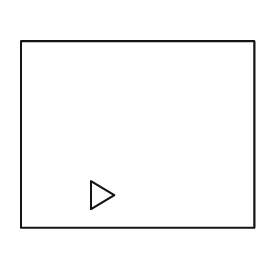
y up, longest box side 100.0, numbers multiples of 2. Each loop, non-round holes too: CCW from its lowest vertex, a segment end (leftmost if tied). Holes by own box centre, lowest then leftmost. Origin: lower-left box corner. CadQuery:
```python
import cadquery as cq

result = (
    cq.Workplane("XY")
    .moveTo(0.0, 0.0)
    .lineTo(100.0, 0.0)
    .lineTo(100.0, 80.0)
    .lineTo(0.0, 80.0)
    .close()
    .moveTo(30.0, 8.0)
    .lineTo(40.0, 14.0)
    .lineTo(30.0, 20.0)
    .close()
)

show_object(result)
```